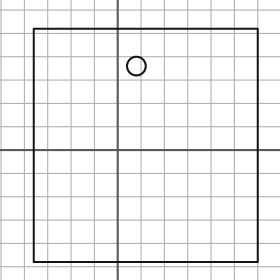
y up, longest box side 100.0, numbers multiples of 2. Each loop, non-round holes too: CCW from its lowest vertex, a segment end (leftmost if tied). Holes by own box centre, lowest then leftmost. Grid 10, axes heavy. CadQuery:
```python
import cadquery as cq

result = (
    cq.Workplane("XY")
    .moveTo(-36.0, -48.0)
    .lineTo(60.0, -48.0)
    .lineTo(60.0, 52.0)
    .lineTo(-36.0, 52.0)
    .close()
    .moveTo(8.0, 36.0)
    .circle(4.0)
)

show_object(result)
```